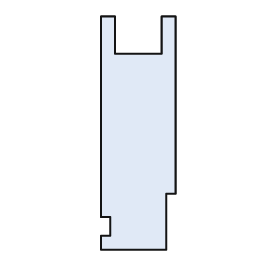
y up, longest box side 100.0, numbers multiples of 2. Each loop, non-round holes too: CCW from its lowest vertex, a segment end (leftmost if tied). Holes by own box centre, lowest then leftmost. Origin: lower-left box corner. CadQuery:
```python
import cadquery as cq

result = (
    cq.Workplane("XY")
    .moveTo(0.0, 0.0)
    .lineTo(28.0, 0.0)
    .lineTo(28.0, 24.0)
    .lineTo(32.0, 24.0)
    .lineTo(32.0, 100.0)
    .lineTo(26.0, 100.0)
    .lineTo(26.0, 84.0)
    .lineTo(6.0, 84.0)
    .lineTo(6.0, 100.0)
    .lineTo(0.0, 100.0)
    .lineTo(0.0, 14.0)
    .lineTo(4.0, 14.0)
    .lineTo(4.0, 6.0)
    .lineTo(0.0, 6.0)
    .close()
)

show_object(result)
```